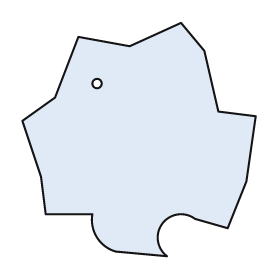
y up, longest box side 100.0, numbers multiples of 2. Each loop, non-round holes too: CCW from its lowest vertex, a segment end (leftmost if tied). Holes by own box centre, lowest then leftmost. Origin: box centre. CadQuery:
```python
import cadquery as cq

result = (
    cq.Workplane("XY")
    .moveTo(12.0, -50.0)
    .threePointArc((10.0, -36.0), (24.0, -34.0))
    .lineTo(38.0, -38.0)
    .lineTo(46.0, -18.0)
    .lineTo(50.0, 10.0)
    .lineTo(34.0, 12.0)
    .lineTo(28.0, 38.0)
    .lineTo(18.0, 50.0)
    .lineTo(-4.0, 40.0)
    .lineTo(-26.0, 44.0)
    .lineTo(-36.0, 18.0)
    .lineTo(-50.0, 8.0)
    .lineTo(-42.0, -16.0)
    .lineTo(-40.0, -32.0)
    .lineTo(-20.0, -32.0)
    .threePointArc((-18.0, -42.0), (-10.0, -48.0))
    .close()
    .moveTo(-18.0, 24.0)
    .circle(2.0)
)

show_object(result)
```